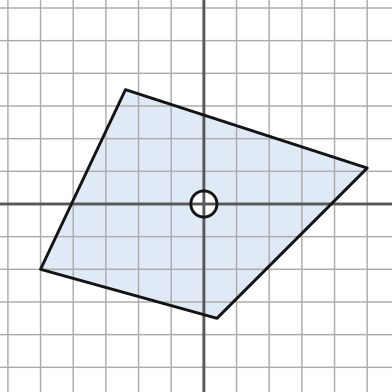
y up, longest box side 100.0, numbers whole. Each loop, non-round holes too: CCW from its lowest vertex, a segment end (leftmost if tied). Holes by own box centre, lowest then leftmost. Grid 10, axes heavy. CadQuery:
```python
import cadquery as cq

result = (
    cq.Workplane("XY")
    .moveTo(4.0, -35.0)
    .lineTo(50.0, 11.0)
    .lineTo(-24.0, 35.0)
    .lineTo(-50.0, -20.0)
    .close()
    .moveTo(0.0, 0.0)
    .circle(4.0)
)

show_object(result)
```